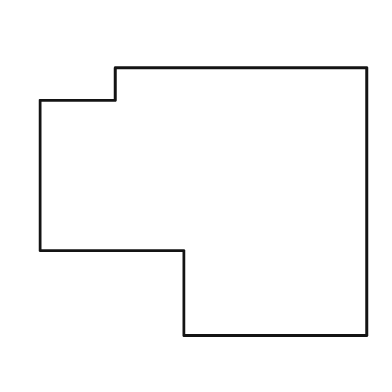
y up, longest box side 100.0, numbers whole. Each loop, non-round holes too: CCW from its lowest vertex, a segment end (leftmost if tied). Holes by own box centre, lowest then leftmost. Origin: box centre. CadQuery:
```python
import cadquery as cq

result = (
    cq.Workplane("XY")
    .moveTo(-6.0, -41.0)
    .lineTo(50.0, -41.0)
    .lineTo(50.0, 41.0)
    .lineTo(-27.0, 41.0)
    .lineTo(-27.0, 31.0)
    .lineTo(-50.0, 31.0)
    .lineTo(-50.0, -15.0)
    .lineTo(-6.0, -15.0)
    .close()
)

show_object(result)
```